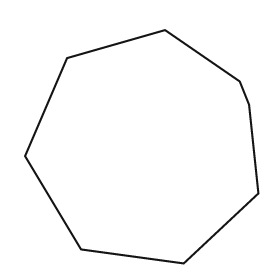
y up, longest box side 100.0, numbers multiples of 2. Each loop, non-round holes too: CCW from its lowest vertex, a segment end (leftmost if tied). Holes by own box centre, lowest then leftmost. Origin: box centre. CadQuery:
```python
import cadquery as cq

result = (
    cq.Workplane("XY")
    .moveTo(18.0, -50.0)
    .lineTo(50.0, -20.0)
    .lineTo(46.0, 18.0)
    .lineTo(42.0, 28.0)
    .lineTo(10.0, 50.0)
    .lineTo(-32.0, 38.0)
    .lineTo(-50.0, -4.0)
    .lineTo(-26.0, -44.0)
    .close()
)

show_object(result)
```